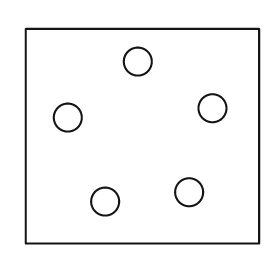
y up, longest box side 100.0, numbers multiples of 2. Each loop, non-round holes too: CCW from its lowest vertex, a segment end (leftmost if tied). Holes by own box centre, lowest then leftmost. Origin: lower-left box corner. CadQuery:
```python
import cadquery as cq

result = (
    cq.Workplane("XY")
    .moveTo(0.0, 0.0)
    .lineTo(100.0, 0.0)
    .lineTo(100.0, 92.0)
    .lineTo(0.0, 92.0)
    .close()
    .moveTo(34.0, 18.0)
    .circle(6.0)
    .moveTo(70.0, 22.0)
    .circle(6.0)
    .moveTo(18.0, 54.0)
    .circle(6.0)
    .moveTo(80.0, 58.0)
    .circle(6.0)
    .moveTo(48.0, 78.0)
    .circle(6.0)
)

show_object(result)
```